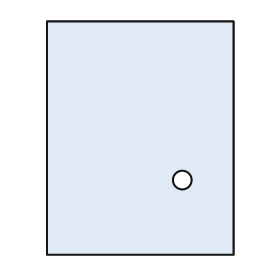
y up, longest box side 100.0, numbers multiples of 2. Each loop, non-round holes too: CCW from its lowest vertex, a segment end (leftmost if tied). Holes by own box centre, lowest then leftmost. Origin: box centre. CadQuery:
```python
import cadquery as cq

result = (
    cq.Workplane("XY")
    .moveTo(-40.0, -50.0)
    .lineTo(40.0, -50.0)
    .lineTo(40.0, 50.0)
    .lineTo(-40.0, 50.0)
    .close()
    .moveTo(18.0, -18.0)
    .circle(4.0)
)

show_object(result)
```